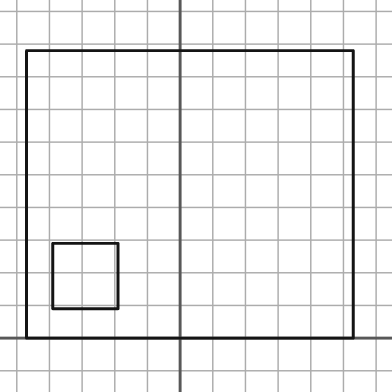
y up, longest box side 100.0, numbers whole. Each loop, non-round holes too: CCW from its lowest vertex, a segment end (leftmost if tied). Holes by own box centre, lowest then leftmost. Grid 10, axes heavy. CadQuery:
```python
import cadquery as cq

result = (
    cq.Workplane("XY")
    .moveTo(-47.0, 0.0)
    .lineTo(53.0, 0.0)
    .lineTo(53.0, 88.0)
    .lineTo(-47.0, 88.0)
    .close()
    .moveTo(-39.0, 9.0)
    .lineTo(-19.0, 9.0)
    .lineTo(-19.0, 29.0)
    .lineTo(-39.0, 29.0)
    .close()
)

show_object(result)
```